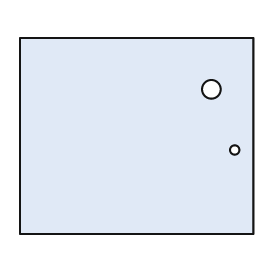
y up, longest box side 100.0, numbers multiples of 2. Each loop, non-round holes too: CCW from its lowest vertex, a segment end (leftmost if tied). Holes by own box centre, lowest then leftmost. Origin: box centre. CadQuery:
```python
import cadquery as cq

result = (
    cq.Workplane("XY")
    .moveTo(-50.0, -42.0)
    .lineTo(50.0, -42.0)
    .lineTo(50.0, 42.0)
    .lineTo(-50.0, 42.0)
    .close()
    .moveTo(42.0, -6.0)
    .circle(2.0)
    .moveTo(32.0, 20.0)
    .circle(4.0)
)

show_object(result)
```